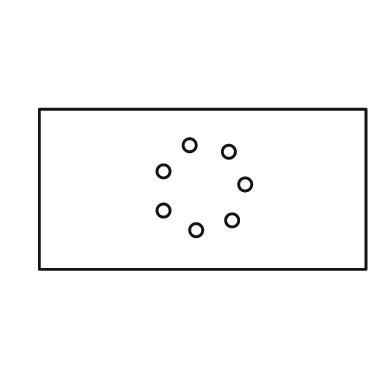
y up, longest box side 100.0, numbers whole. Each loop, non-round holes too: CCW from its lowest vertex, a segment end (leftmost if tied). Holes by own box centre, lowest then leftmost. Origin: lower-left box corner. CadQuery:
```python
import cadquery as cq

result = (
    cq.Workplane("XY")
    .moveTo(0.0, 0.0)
    .lineTo(100.0, 0.0)
    .lineTo(100.0, 49.0)
    .lineTo(0.0, 49.0)
    .close()
    .moveTo(48.0, 12.0)
    .circle(2.0)
    .moveTo(59.0, 15.0)
    .circle(2.0)
    .moveTo(38.0, 18.0)
    .circle(2.0)
    .moveTo(63.0, 26.0)
    .circle(2.0)
    .moveTo(38.0, 30.0)
    .circle(2.0)
    .moveTo(58.0, 36.0)
    .circle(2.0)
    .moveTo(46.0, 38.0)
    .circle(2.0)
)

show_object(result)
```